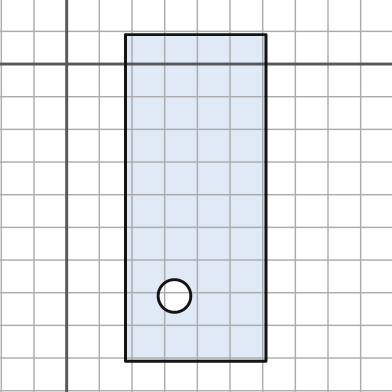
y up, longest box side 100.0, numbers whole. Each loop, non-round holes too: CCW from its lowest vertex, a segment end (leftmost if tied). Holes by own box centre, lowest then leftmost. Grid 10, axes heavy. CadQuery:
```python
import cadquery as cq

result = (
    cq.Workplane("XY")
    .moveTo(18.0, -91.0)
    .lineTo(61.0, -91.0)
    .lineTo(61.0, 9.0)
    .lineTo(18.0, 9.0)
    .close()
    .moveTo(33.0, -71.0)
    .circle(5.0)
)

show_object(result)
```